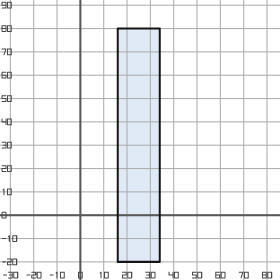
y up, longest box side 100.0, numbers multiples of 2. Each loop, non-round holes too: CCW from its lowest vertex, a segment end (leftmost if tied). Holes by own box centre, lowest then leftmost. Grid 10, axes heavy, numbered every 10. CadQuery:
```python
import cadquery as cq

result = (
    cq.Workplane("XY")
    .moveTo(16.0, -20.0)
    .lineTo(34.0, -20.0)
    .lineTo(34.0, 80.0)
    .lineTo(16.0, 80.0)
    .close()
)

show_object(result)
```